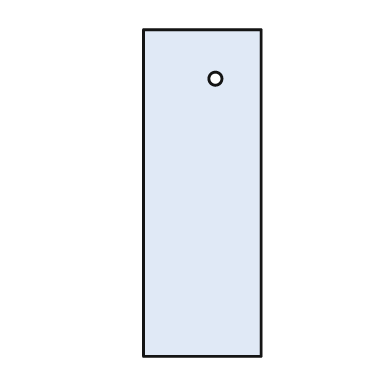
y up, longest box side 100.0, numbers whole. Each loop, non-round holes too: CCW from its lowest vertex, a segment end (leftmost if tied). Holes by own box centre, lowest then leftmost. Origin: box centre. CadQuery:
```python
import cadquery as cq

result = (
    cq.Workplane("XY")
    .moveTo(-18.0, -50.0)
    .lineTo(18.0, -50.0)
    .lineTo(18.0, 50.0)
    .lineTo(-18.0, 50.0)
    .close()
    .moveTo(4.0, 35.0)
    .circle(2.0)
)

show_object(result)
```